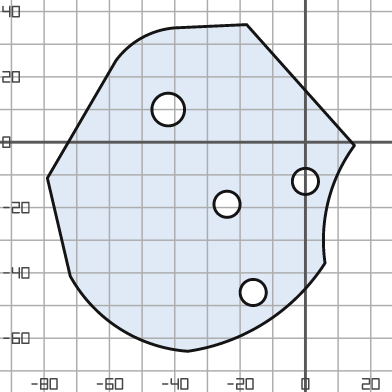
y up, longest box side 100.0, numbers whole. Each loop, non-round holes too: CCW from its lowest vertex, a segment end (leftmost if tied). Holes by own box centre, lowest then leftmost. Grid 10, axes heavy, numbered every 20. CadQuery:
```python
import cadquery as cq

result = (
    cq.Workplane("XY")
    .moveTo(-36.0, -64.0)
    .threePointArc((-12.0, -55.0), (6.0, -37.0))
    .threePointArc((7.0, -18.0), (15.0, -1.0))
    .lineTo(-18.0, 36.0)
    .lineTo(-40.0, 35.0)
    .threePointArc((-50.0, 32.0), (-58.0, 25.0))
    .lineTo(-79.0, -11.0)
    .lineTo(-72.0, -41.0)
    .threePointArc((-57.0, -57.0), (-36.0, -64.0))
    .close()
    .moveTo(-16.0, -46.0)
    .circle(4.0)
    .moveTo(-24.0, -19.0)
    .circle(4.0)
    .moveTo(0.0, -12.0)
    .circle(4.0)
    .moveTo(-42.0, 10.0)
    .circle(5.0)
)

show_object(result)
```